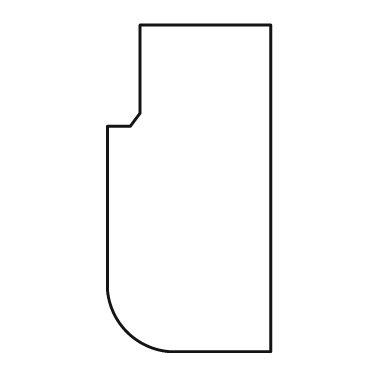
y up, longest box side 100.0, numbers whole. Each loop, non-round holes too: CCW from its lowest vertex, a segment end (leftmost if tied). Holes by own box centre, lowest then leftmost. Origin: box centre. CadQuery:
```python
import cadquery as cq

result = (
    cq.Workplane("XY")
    .moveTo(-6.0, -50.0)
    .lineTo(25.0, -50.0)
    .lineTo(25.0, 50.0)
    .lineTo(-15.0, 50.0)
    .lineTo(-15.0, 23.0)
    .lineTo(-18.0, 19.0)
    .lineTo(-25.0, 19.0)
    .lineTo(-25.0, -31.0)
    .threePointArc((-19.0, -44.0), (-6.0, -50.0))
    .close()
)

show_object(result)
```